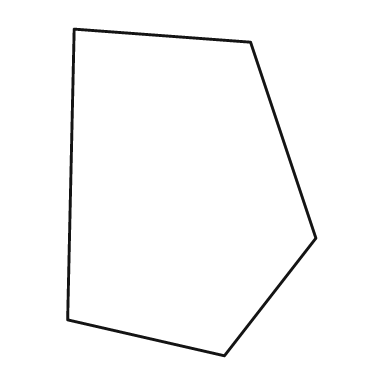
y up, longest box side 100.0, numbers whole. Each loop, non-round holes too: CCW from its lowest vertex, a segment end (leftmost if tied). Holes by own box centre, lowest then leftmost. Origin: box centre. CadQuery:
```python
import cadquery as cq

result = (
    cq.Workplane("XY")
    .moveTo(10.0, -50.0)
    .lineTo(38.0, -14.0)
    .lineTo(18.0, 46.0)
    .lineTo(-36.0, 50.0)
    .lineTo(-38.0, -39.0)
    .close()
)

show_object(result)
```